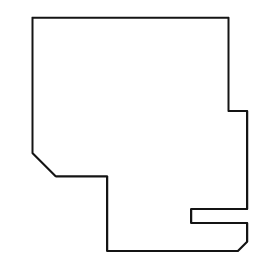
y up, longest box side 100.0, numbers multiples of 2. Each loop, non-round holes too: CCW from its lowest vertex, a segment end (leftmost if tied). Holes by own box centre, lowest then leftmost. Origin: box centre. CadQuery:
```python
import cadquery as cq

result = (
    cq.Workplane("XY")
    .moveTo(-14.0, -50.0)
    .lineTo(42.0, -50.0)
    .lineTo(46.0, -46.0)
    .lineTo(46.0, -38.0)
    .lineTo(22.0, -38.0)
    .lineTo(22.0, -32.0)
    .lineTo(46.0, -32.0)
    .lineTo(46.0, 10.0)
    .lineTo(38.0, 10.0)
    .lineTo(38.0, 50.0)
    .lineTo(-46.0, 50.0)
    .lineTo(-46.0, -8.0)
    .lineTo(-36.0, -18.0)
    .lineTo(-14.0, -18.0)
    .close()
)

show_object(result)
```